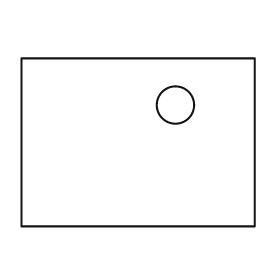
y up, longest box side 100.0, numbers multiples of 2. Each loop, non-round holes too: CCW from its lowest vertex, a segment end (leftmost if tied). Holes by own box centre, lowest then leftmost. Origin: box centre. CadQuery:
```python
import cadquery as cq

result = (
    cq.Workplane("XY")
    .moveTo(-50.0, -36.0)
    .lineTo(50.0, -36.0)
    .lineTo(50.0, 36.0)
    .lineTo(-50.0, 36.0)
    .close()
    .moveTo(16.0, 16.0)
    .circle(8.0)
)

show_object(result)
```